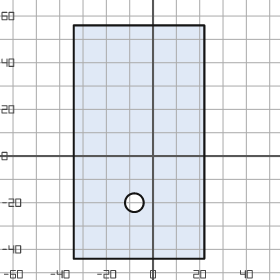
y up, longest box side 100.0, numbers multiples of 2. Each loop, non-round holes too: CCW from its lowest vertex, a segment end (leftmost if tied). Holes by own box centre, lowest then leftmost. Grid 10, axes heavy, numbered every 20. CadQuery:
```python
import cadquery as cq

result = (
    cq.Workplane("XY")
    .moveTo(-34.0, -44.0)
    .lineTo(22.0, -44.0)
    .lineTo(22.0, 56.0)
    .lineTo(-34.0, 56.0)
    .close()
    .moveTo(-8.0, -20.0)
    .circle(4.0)
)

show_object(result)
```